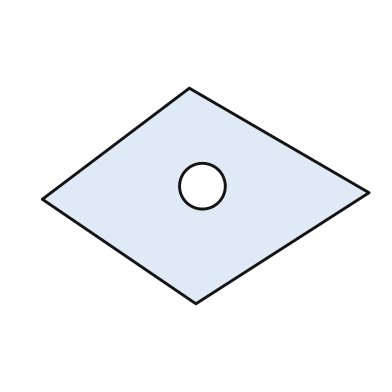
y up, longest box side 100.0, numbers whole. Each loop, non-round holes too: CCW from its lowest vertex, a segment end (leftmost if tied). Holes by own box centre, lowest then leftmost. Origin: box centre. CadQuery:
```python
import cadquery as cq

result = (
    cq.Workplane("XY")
    .moveTo(-3.0, -33.0)
    .lineTo(50.0, 1.0)
    .lineTo(-5.0, 33.0)
    .lineTo(-50.0, -1.0)
    .close()
    .moveTo(-1.0, 3.0)
    .circle(7.0)
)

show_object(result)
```